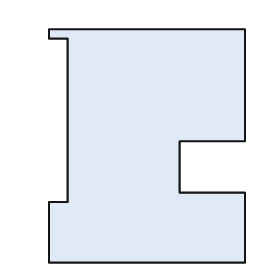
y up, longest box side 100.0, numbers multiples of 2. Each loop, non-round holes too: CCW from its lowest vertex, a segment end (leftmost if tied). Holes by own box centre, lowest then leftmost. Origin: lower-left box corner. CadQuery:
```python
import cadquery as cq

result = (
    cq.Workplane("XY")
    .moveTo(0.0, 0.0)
    .lineTo(84.0, 0.0)
    .lineTo(84.0, 30.0)
    .lineTo(56.0, 30.0)
    .lineTo(56.0, 52.0)
    .lineTo(84.0, 52.0)
    .lineTo(84.0, 100.0)
    .lineTo(0.0, 100.0)
    .lineTo(0.0, 96.0)
    .lineTo(8.0, 96.0)
    .lineTo(8.0, 26.0)
    .lineTo(0.0, 26.0)
    .close()
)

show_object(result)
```